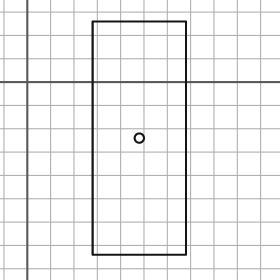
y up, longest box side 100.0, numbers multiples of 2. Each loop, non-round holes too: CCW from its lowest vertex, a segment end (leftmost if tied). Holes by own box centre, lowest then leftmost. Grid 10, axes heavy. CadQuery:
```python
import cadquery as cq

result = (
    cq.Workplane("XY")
    .moveTo(28.0, -74.0)
    .lineTo(68.0, -74.0)
    .lineTo(68.0, 26.0)
    .lineTo(28.0, 26.0)
    .close()
    .moveTo(48.0, -24.0)
    .circle(2.0)
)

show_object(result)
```